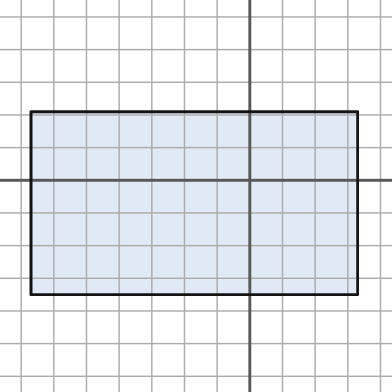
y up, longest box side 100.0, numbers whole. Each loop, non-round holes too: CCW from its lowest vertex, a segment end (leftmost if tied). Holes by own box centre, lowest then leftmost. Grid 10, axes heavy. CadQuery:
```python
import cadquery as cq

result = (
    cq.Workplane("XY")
    .moveTo(-67.0, -35.0)
    .lineTo(33.0, -35.0)
    .lineTo(33.0, 21.0)
    .lineTo(-67.0, 21.0)
    .close()
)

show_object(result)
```